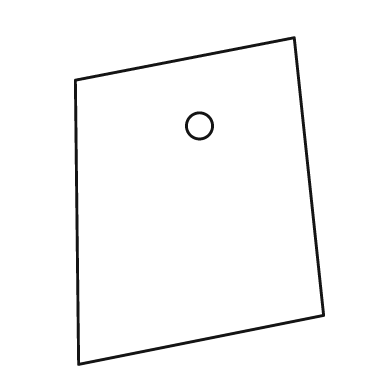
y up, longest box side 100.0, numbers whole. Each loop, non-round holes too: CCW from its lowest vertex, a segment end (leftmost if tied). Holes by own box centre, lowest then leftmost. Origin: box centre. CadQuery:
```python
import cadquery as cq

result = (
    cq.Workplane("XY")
    .moveTo(-37.0, -50.0)
    .lineTo(38.0, -35.0)
    .lineTo(29.0, 50.0)
    .lineTo(-38.0, 37.0)
    .close()
    .moveTo(0.0, 23.0)
    .circle(4.0)
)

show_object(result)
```